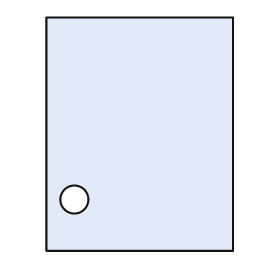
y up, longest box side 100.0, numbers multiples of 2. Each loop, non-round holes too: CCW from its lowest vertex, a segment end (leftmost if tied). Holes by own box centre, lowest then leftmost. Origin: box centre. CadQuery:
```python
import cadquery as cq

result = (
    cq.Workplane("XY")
    .moveTo(-40.0, -50.0)
    .lineTo(40.0, -50.0)
    .lineTo(40.0, 50.0)
    .lineTo(-40.0, 50.0)
    .close()
    .moveTo(-28.0, -28.0)
    .circle(6.0)
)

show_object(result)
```